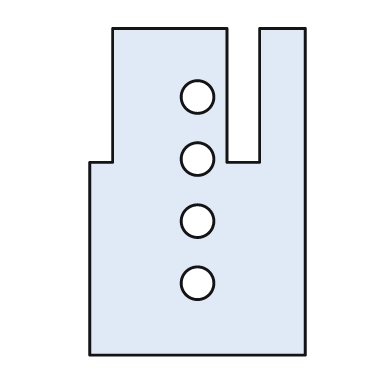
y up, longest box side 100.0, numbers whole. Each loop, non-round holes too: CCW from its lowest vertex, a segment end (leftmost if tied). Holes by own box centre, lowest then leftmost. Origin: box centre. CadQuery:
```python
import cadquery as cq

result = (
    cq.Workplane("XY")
    .moveTo(-33.0, -50.0)
    .lineTo(33.0, -50.0)
    .lineTo(33.0, 50.0)
    .lineTo(19.0, 50.0)
    .lineTo(19.0, 9.0)
    .lineTo(9.0, 9.0)
    .lineTo(9.0, 50.0)
    .lineTo(-26.0, 50.0)
    .lineTo(-26.0, 9.0)
    .lineTo(-33.0, 9.0)
    .close()
    .moveTo(0.0, -28.0)
    .circle(5.0)
    .moveTo(0.0, -9.0)
    .circle(5.0)
    .moveTo(0.0, 10.0)
    .circle(5.0)
    .moveTo(0.0, 29.0)
    .circle(5.0)
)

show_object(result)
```